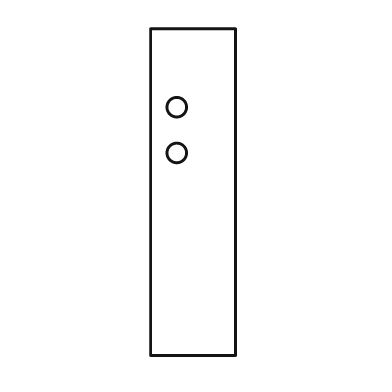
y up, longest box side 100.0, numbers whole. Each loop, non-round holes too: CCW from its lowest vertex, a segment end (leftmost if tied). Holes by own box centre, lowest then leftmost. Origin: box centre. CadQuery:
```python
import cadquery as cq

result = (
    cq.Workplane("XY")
    .moveTo(-13.0, -50.0)
    .lineTo(13.0, -50.0)
    .lineTo(13.0, 50.0)
    .lineTo(-13.0, 50.0)
    .close()
    .moveTo(-5.0, 12.0)
    .circle(3.0)
    .moveTo(-5.0, 26.0)
    .circle(3.0)
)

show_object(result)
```